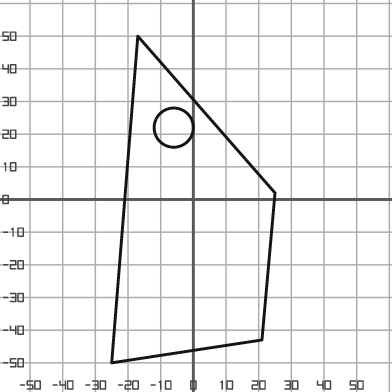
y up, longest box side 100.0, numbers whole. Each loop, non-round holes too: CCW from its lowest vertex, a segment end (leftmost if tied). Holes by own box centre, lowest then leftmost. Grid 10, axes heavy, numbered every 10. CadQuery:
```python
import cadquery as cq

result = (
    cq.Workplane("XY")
    .moveTo(-25.0, -50.0)
    .lineTo(21.0, -43.0)
    .lineTo(25.0, 2.0)
    .lineTo(-17.0, 50.0)
    .close()
    .moveTo(-6.0, 22.0)
    .circle(6.0)
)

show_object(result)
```